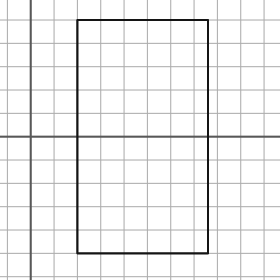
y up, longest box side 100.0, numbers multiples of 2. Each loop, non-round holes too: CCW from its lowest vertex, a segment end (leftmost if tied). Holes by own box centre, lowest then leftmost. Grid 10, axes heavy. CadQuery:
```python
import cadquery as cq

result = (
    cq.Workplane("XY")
    .moveTo(20.0, -50.0)
    .lineTo(76.0, -50.0)
    .lineTo(76.0, 50.0)
    .lineTo(20.0, 50.0)
    .close()
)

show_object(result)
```